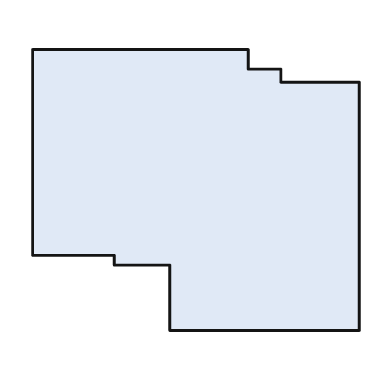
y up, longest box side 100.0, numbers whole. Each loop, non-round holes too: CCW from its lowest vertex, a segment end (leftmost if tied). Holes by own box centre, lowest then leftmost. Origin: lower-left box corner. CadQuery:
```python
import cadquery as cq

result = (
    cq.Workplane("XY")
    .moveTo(42.0, 0.0)
    .lineTo(100.0, 0.0)
    .lineTo(100.0, 76.0)
    .lineTo(76.0, 76.0)
    .lineTo(76.0, 80.0)
    .lineTo(66.0, 80.0)
    .lineTo(66.0, 86.0)
    .lineTo(0.0, 86.0)
    .lineTo(0.0, 23.0)
    .lineTo(25.0, 23.0)
    .lineTo(25.0, 20.0)
    .lineTo(42.0, 20.0)
    .close()
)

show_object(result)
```